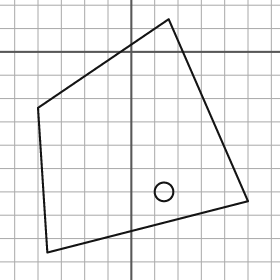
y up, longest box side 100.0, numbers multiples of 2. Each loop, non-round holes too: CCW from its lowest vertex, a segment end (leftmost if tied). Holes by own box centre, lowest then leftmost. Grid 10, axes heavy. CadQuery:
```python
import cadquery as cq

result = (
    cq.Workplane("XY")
    .moveTo(-36.0, -86.0)
    .lineTo(50.0, -64.0)
    .lineTo(16.0, 14.0)
    .lineTo(-40.0, -24.0)
    .close()
    .moveTo(14.0, -60.0)
    .circle(4.0)
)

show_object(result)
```